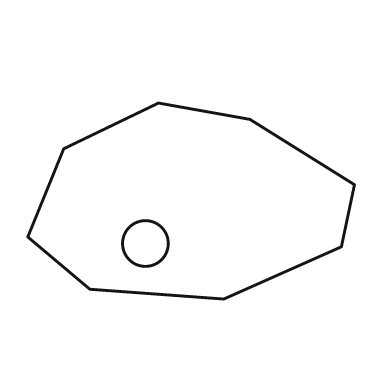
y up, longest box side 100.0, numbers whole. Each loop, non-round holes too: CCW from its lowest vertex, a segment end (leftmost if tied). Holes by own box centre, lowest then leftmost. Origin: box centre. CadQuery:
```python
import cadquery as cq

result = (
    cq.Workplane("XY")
    .moveTo(10.0, -30.0)
    .lineTo(46.0, -14.0)
    .lineTo(50.0, 5.0)
    .lineTo(18.0, 25.0)
    .lineTo(-10.0, 30.0)
    .lineTo(-39.0, 16.0)
    .lineTo(-50.0, -11.0)
    .lineTo(-31.0, -27.0)
    .close()
    .moveTo(-14.0, -13.0)
    .circle(7.0)
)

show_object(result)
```